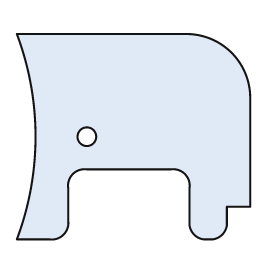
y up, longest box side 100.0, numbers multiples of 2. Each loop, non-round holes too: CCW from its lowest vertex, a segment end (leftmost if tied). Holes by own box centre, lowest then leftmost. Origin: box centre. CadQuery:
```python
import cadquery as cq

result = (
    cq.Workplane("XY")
    .moveTo(-50.0, -44.0)
    .lineTo(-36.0, -44.0)
    .threePointArc((-30.0, -42.0), (-28.0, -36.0))
    .lineTo(-28.0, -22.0)
    .threePointArc((-26.0, -16.0), (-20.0, -14.0))
    .lineTo(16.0, -14.0)
    .threePointArc((22.0, -16.0), (24.0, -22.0))
    .lineTo(24.0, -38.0)
    .threePointArc((26.0, -42.0), (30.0, -44.0))
    .lineTo(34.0, -44.0)
    .threePointArc((38.0, -42.0), (40.0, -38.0))
    .lineTo(40.0, -30.0)
    .lineTo(50.0, -30.0)
    .lineTo(50.0, 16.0)
    .threePointArc((42.0, 36.0), (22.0, 44.0))
    .lineTo(-50.0, 44.0)
    .threePointArc((-42.0, 0.0), (-50.0, -44.0))
    .close()
    .moveTo(-20.0, 0.0)
    .circle(4.0)
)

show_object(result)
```